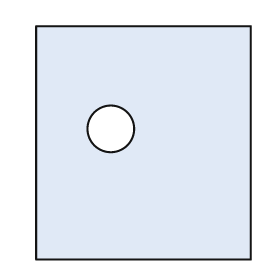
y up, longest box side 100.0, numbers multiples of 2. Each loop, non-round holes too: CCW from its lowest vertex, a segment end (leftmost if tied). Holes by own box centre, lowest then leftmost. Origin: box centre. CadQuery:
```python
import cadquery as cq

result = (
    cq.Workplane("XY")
    .moveTo(-46.0, -50.0)
    .lineTo(46.0, -50.0)
    .lineTo(46.0, 50.0)
    .lineTo(-46.0, 50.0)
    .close()
    .moveTo(-14.0, 6.0)
    .circle(10.0)
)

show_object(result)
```